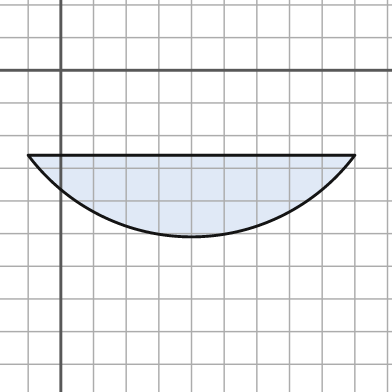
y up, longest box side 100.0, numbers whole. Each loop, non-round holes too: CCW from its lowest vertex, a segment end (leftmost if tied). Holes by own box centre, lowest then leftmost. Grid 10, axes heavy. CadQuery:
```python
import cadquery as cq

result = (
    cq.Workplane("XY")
    .moveTo(-10.0, -26.0)
    .threePointArc((40.0, -51.0), (90.0, -26.0))
    .close()
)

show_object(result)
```